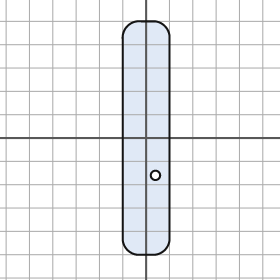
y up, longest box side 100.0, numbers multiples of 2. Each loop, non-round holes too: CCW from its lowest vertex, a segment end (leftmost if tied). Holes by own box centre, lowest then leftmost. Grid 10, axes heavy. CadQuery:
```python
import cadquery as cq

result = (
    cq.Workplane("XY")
    .moveTo(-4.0, -50.0)
    .lineTo(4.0, -50.0)
    .threePointArc((8.0, -48.0), (10.0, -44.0))
    .lineTo(10.0, 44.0)
    .threePointArc((8.0, 48.0), (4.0, 50.0))
    .lineTo(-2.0, 50.0)
    .threePointArc((-8.0, 48.0), (-10.0, 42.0))
    .lineTo(-10.0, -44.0)
    .threePointArc((-8.0, -48.0), (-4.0, -50.0))
    .close()
    .moveTo(4.0, -16.0)
    .circle(2.0)
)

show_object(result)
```